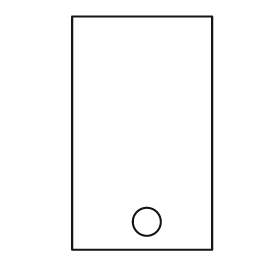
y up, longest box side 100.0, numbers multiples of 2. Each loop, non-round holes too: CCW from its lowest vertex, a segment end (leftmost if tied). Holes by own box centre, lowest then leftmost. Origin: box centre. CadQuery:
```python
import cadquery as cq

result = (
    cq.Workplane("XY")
    .moveTo(-30.0, -50.0)
    .lineTo(30.0, -50.0)
    .lineTo(30.0, 50.0)
    .lineTo(-30.0, 50.0)
    .close()
    .moveTo(2.0, -38.0)
    .circle(6.0)
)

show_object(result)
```